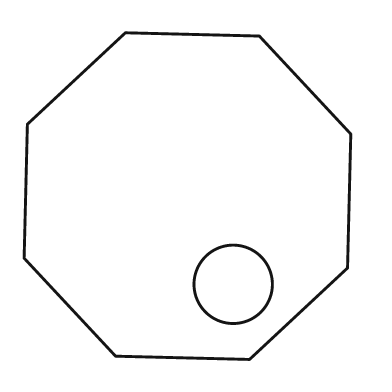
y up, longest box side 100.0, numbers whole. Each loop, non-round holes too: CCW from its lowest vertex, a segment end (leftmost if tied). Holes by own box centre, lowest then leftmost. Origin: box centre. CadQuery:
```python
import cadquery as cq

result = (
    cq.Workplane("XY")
    .moveTo(19.0, -50.0)
    .lineTo(49.0, -22.0)
    .lineTo(50.0, 19.0)
    .lineTo(22.0, 49.0)
    .lineTo(-19.0, 50.0)
    .lineTo(-49.0, 22.0)
    .lineTo(-50.0, -19.0)
    .lineTo(-22.0, -49.0)
    .close()
    .moveTo(14.0, -27.0)
    .circle(12.0)
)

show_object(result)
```